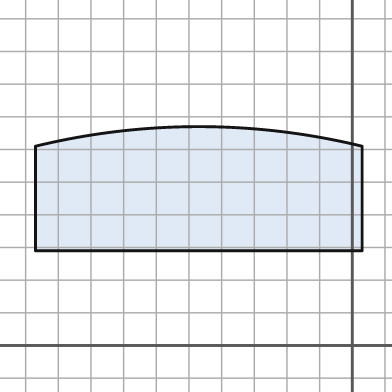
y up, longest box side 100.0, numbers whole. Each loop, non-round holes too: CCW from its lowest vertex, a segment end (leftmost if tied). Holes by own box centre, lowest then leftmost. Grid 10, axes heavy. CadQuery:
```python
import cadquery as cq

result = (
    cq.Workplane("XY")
    .moveTo(-97.0, 29.0)
    .lineTo(3.0, 29.0)
    .lineTo(3.0, 61.0)
    .threePointArc((-47.0, 67.0), (-97.0, 61.0))
    .close()
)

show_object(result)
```